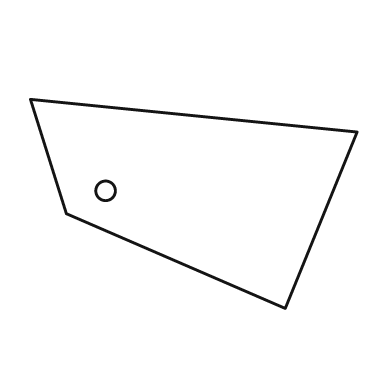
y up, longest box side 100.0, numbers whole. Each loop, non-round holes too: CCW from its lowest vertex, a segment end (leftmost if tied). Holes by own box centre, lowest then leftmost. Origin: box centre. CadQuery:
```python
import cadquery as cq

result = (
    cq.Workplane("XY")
    .moveTo(28.0, -32.0)
    .lineTo(50.0, 22.0)
    .lineTo(-50.0, 32.0)
    .lineTo(-39.0, -3.0)
    .close()
    .moveTo(-27.0, 4.0)
    .circle(3.0)
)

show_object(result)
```